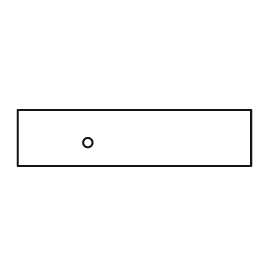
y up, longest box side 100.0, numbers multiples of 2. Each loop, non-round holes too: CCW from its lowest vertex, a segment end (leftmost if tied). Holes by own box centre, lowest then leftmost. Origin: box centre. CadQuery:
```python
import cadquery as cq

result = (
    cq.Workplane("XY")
    .moveTo(-50.0, -12.0)
    .lineTo(50.0, -12.0)
    .lineTo(50.0, 12.0)
    .lineTo(-50.0, 12.0)
    .close()
    .moveTo(-20.0, -2.0)
    .circle(2.0)
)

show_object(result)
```